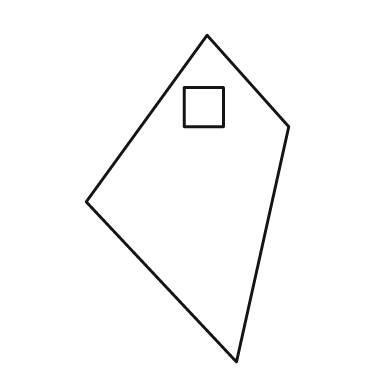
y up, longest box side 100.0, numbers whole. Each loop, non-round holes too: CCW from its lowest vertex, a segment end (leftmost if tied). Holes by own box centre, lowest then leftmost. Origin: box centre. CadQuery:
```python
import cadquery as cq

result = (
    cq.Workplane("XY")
    .moveTo(15.0, -50.0)
    .lineTo(31.0, 22.0)
    .lineTo(6.0, 50.0)
    .lineTo(-31.0, -1.0)
    .close()
    .moveTo(-1.0, 22.0)
    .lineTo(11.0, 22.0)
    .lineTo(11.0, 34.0)
    .lineTo(-1.0, 34.0)
    .close()
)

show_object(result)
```